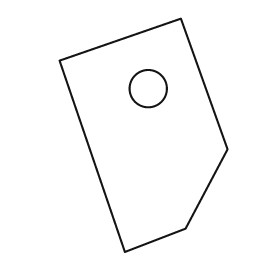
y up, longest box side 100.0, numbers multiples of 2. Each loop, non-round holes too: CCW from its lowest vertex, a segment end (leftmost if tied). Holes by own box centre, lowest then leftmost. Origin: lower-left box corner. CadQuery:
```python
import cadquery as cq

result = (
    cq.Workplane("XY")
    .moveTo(28.0, 0.0)
    .lineTo(54.0, 10.0)
    .lineTo(72.0, 44.0)
    .lineTo(52.0, 100.0)
    .lineTo(0.0, 82.0)
    .close()
    .moveTo(38.0, 70.0)
    .circle(8.0)
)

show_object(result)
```